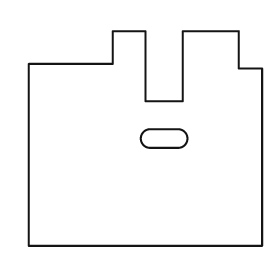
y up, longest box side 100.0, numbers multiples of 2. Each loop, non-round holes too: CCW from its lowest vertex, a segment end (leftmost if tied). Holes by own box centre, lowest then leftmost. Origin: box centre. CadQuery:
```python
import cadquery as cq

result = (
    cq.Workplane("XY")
    .moveTo(-50.0, -46.0)
    .lineTo(50.0, -46.0)
    .lineTo(50.0, 30.0)
    .lineTo(40.0, 30.0)
    .lineTo(40.0, 46.0)
    .lineTo(16.0, 46.0)
    .lineTo(16.0, 16.0)
    .lineTo(0.0, 16.0)
    .lineTo(0.0, 46.0)
    .lineTo(-14.0, 46.0)
    .lineTo(-14.0, 32.0)
    .lineTo(-50.0, 32.0)
    .close()
    .moveTo(2.0, -4.0)
    .lineTo(14.0, -4.0)
    .threePointArc((18.0, 0.0), (14.0, 4.0))
    .lineTo(2.0, 4.0)
    .threePointArc((-2.0, 0.0), (2.0, -4.0))
    .close()
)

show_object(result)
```